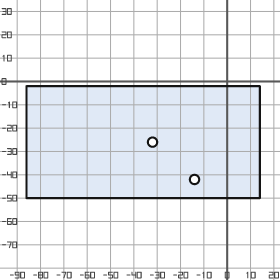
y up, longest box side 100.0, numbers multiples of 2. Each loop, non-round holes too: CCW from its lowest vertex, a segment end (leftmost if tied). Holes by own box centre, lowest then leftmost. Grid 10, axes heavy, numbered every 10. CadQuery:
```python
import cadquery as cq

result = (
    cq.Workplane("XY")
    .moveTo(-86.0, -50.0)
    .lineTo(14.0, -50.0)
    .lineTo(14.0, -2.0)
    .lineTo(-86.0, -2.0)
    .close()
    .moveTo(-14.0, -42.0)
    .circle(2.0)
    .moveTo(-32.0, -26.0)
    .circle(2.0)
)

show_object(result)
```